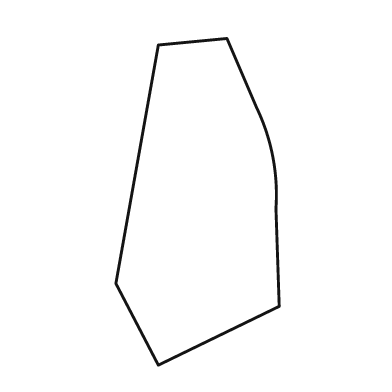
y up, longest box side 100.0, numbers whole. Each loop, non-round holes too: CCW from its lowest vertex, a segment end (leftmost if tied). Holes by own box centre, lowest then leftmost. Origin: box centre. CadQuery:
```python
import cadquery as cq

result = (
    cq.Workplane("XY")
    .moveTo(-12.0, -50.0)
    .lineTo(25.0, -32.0)
    .lineTo(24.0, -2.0)
    .threePointArc((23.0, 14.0), (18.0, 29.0))
    .lineTo(9.0, 50.0)
    .lineTo(-12.0, 48.0)
    .lineTo(-25.0, -25.0)
    .close()
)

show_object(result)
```